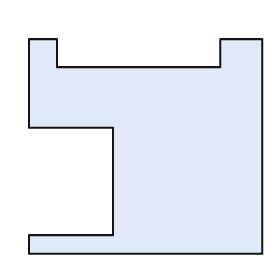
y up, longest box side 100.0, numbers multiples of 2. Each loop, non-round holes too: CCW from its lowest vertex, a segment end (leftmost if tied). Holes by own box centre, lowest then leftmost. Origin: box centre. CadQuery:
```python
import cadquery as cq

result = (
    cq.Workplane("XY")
    .moveTo(-50.0, -46.0)
    .lineTo(50.0, -46.0)
    .lineTo(50.0, 46.0)
    .lineTo(32.0, 46.0)
    .lineTo(32.0, 34.0)
    .lineTo(-38.0, 34.0)
    .lineTo(-38.0, 46.0)
    .lineTo(-50.0, 46.0)
    .lineTo(-50.0, 8.0)
    .lineTo(-14.0, 8.0)
    .lineTo(-14.0, -38.0)
    .lineTo(-50.0, -38.0)
    .close()
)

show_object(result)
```